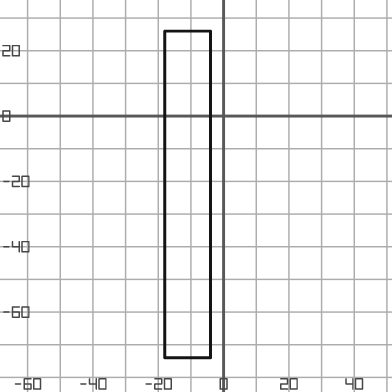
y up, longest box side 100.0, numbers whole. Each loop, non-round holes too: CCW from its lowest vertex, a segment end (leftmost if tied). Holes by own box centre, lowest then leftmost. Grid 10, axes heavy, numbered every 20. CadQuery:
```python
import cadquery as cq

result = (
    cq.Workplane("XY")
    .moveTo(-18.0, -74.0)
    .lineTo(-4.0, -74.0)
    .lineTo(-4.0, 26.0)
    .lineTo(-18.0, 26.0)
    .close()
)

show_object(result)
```